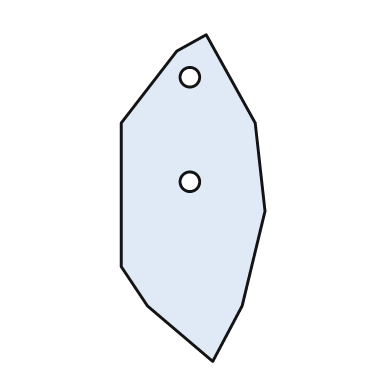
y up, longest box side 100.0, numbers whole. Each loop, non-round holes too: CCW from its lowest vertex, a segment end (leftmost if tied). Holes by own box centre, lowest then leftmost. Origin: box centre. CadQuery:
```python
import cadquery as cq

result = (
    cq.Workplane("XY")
    .moveTo(6.0, -50.0)
    .lineTo(15.0, -33.0)
    .lineTo(22.0, -4.0)
    .lineTo(19.0, 23.0)
    .lineTo(4.0, 50.0)
    .lineTo(-5.0, 45.0)
    .lineTo(-22.0, 23.0)
    .lineTo(-22.0, -21.0)
    .lineTo(-14.0, -33.0)
    .close()
    .moveTo(-1.0, 5.0)
    .circle(3.0)
    .moveTo(-1.0, 37.0)
    .circle(3.0)
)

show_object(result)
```